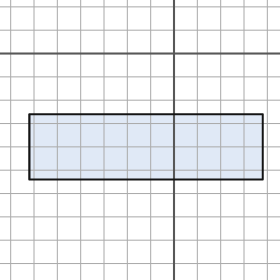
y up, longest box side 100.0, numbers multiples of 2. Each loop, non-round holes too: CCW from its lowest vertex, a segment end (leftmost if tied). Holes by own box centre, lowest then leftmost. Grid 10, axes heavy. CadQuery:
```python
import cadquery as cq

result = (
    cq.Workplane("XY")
    .moveTo(-62.0, -54.0)
    .lineTo(38.0, -54.0)
    .lineTo(38.0, -26.0)
    .lineTo(-62.0, -26.0)
    .close()
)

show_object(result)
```